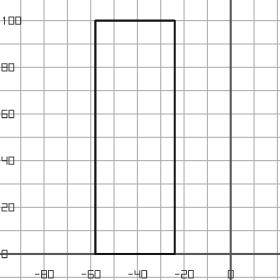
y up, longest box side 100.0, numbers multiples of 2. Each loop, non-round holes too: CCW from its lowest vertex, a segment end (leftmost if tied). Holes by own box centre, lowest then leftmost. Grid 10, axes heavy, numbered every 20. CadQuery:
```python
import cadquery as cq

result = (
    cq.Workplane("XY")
    .moveTo(-58.0, 0.0)
    .lineTo(-24.0, 0.0)
    .lineTo(-24.0, 100.0)
    .lineTo(-58.0, 100.0)
    .close()
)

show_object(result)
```